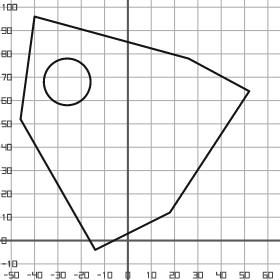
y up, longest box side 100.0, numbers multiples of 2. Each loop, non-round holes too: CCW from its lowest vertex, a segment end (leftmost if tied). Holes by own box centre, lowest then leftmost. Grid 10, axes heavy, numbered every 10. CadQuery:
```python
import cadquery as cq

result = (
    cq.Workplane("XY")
    .moveTo(-14.0, -4.0)
    .lineTo(18.0, 12.0)
    .lineTo(52.0, 64.0)
    .lineTo(26.0, 78.0)
    .lineTo(-40.0, 96.0)
    .lineTo(-46.0, 52.0)
    .close()
    .moveTo(-26.0, 68.0)
    .circle(10.0)
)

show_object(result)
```